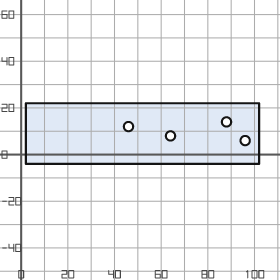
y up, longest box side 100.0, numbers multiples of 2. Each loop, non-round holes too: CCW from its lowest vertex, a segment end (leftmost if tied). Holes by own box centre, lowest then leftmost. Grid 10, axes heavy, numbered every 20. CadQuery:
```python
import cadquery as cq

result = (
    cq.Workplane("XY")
    .moveTo(2.0, -4.0)
    .lineTo(102.0, -4.0)
    .lineTo(102.0, 22.0)
    .lineTo(2.0, 22.0)
    .close()
    .moveTo(96.0, 6.0)
    .circle(2.0)
    .moveTo(64.0, 8.0)
    .circle(2.0)
    .moveTo(46.0, 12.0)
    .circle(2.0)
    .moveTo(88.0, 14.0)
    .circle(2.0)
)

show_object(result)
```